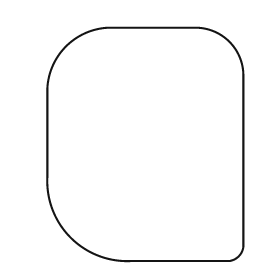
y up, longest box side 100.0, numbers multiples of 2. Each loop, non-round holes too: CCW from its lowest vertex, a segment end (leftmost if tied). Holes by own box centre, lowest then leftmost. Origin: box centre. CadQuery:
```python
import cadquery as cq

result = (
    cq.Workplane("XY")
    .moveTo(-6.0, -50.0)
    .lineTo(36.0, -50.0)
    .threePointArc((40.0, -48.0), (42.0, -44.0))
    .lineTo(42.0, 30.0)
    .threePointArc((36.0, 44.0), (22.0, 50.0))
    .lineTo(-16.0, 50.0)
    .threePointArc((-34.0, 42.0), (-42.0, 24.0))
    .lineTo(-42.0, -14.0)
    .threePointArc((-32.0, -40.0), (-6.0, -50.0))
    .close()
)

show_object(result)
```